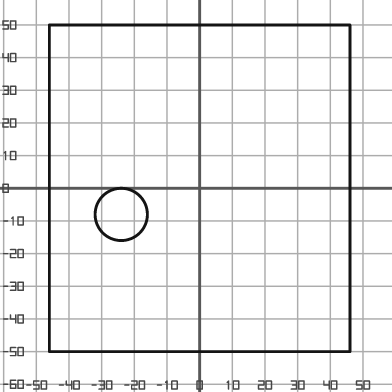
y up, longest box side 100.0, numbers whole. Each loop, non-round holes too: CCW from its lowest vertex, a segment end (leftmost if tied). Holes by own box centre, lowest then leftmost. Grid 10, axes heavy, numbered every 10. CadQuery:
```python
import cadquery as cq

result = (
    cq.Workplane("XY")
    .moveTo(-46.0, -50.0)
    .lineTo(46.0, -50.0)
    .lineTo(46.0, 50.0)
    .lineTo(-46.0, 50.0)
    .close()
    .moveTo(-24.0, -8.0)
    .circle(8.0)
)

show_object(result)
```